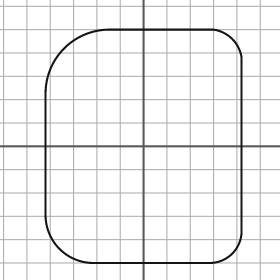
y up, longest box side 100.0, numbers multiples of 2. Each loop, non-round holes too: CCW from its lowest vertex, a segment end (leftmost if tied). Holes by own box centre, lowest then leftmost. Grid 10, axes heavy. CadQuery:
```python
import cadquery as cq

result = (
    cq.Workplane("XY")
    .moveTo(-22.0, -50.0)
    .lineTo(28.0, -50.0)
    .threePointArc((38.0, -46.0), (42.0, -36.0))
    .lineTo(42.0, 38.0)
    .threePointArc((38.0, 46.0), (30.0, 50.0))
    .lineTo(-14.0, 50.0)
    .threePointArc((-34.0, 42.0), (-42.0, 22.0))
    .lineTo(-42.0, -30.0)
    .threePointArc((-36.0, -44.0), (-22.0, -50.0))
    .close()
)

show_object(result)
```